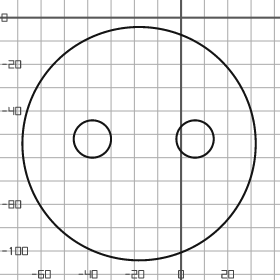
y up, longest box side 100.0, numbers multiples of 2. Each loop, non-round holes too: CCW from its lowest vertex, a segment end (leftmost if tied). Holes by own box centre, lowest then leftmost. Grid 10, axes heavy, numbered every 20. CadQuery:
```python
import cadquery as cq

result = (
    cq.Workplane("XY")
    .moveTo(-18.0, -54.0)
    .circle(50.0)
    .moveTo(-38.0, -52.0)
    .circle(8.0)
    .moveTo(6.0, -52.0)
    .circle(8.0)
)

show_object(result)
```